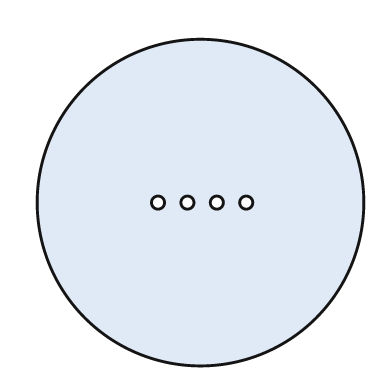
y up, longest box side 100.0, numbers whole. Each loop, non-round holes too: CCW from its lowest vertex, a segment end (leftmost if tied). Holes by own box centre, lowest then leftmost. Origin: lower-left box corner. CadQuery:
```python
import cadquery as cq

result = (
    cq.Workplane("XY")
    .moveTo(50.0, 50.0)
    .circle(50.0)
    .moveTo(37.0, 50.0)
    .circle(2.0)
    .moveTo(46.0, 50.0)
    .circle(2.0)
    .moveTo(55.0, 50.0)
    .circle(2.0)
    .moveTo(64.0, 50.0)
    .circle(2.0)
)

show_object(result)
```